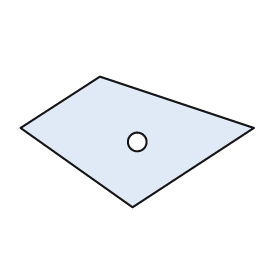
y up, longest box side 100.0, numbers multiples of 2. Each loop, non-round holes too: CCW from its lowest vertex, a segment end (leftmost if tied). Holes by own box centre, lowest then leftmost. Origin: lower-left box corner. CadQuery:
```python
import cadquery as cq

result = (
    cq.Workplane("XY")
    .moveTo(48.0, 0.0)
    .lineTo(100.0, 34.0)
    .lineTo(34.0, 56.0)
    .lineTo(0.0, 34.0)
    .close()
    .moveTo(50.0, 28.0)
    .circle(4.0)
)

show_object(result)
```